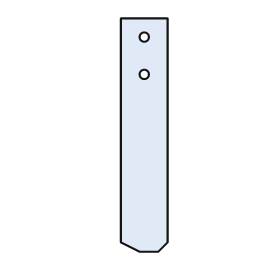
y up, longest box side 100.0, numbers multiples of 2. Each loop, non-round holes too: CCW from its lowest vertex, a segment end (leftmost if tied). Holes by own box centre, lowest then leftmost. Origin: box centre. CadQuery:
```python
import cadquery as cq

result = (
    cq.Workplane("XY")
    .moveTo(-2.0, -50.0)
    .lineTo(6.0, -50.0)
    .lineTo(10.0, -46.0)
    .lineTo(10.0, 50.0)
    .lineTo(-10.0, 50.0)
    .lineTo(-10.0, -46.0)
    .close()
    .moveTo(0.0, 26.0)
    .circle(2.0)
    .moveTo(0.0, 42.0)
    .circle(2.0)
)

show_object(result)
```